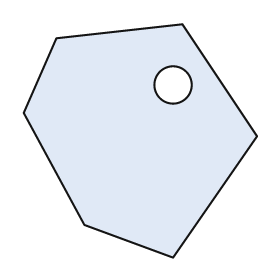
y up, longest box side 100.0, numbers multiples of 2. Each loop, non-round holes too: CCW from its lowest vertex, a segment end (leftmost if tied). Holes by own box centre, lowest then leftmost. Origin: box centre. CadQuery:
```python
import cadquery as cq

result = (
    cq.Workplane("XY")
    .moveTo(14.0, -50.0)
    .lineTo(50.0, 2.0)
    .lineTo(18.0, 50.0)
    .lineTo(-36.0, 44.0)
    .lineTo(-50.0, 12.0)
    .lineTo(-24.0, -36.0)
    .close()
    .moveTo(14.0, 24.0)
    .circle(8.0)
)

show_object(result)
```